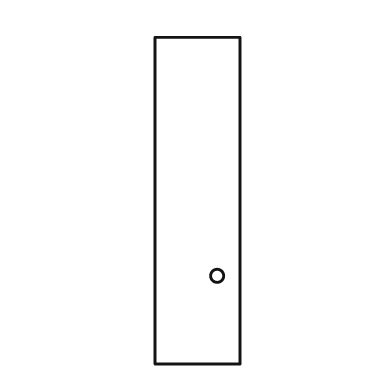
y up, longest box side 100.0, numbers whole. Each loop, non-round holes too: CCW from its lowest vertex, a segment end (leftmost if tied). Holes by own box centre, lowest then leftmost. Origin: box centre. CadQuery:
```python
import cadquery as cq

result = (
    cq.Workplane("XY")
    .moveTo(-13.0, -50.0)
    .lineTo(13.0, -50.0)
    .lineTo(13.0, 50.0)
    .lineTo(-13.0, 50.0)
    .close()
    .moveTo(6.0, -23.0)
    .circle(2.0)
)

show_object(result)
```